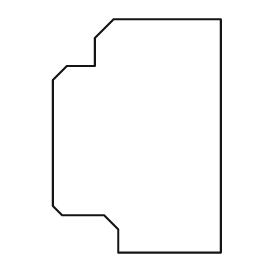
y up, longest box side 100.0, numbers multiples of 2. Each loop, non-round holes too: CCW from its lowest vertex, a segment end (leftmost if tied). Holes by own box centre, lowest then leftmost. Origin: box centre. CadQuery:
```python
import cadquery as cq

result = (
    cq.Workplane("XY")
    .moveTo(-8.0, -50.0)
    .lineTo(36.0, -50.0)
    .lineTo(36.0, 50.0)
    .lineTo(-10.0, 50.0)
    .lineTo(-18.0, 42.0)
    .lineTo(-18.0, 30.0)
    .lineTo(-30.0, 30.0)
    .lineTo(-36.0, 24.0)
    .lineTo(-36.0, -30.0)
    .lineTo(-32.0, -34.0)
    .lineTo(-14.0, -34.0)
    .lineTo(-8.0, -40.0)
    .close()
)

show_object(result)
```